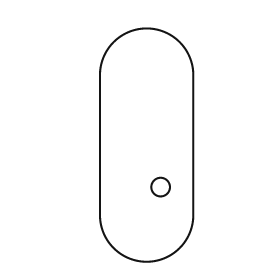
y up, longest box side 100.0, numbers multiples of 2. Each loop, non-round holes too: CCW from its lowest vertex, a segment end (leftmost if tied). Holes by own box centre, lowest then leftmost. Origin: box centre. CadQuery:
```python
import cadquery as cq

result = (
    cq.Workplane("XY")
    .moveTo(-20.0, -30.0)
    .threePointArc((0.0, -50.0), (20.0, -30.0))
    .lineTo(20.0, 30.0)
    .threePointArc((0.0, 50.0), (-20.0, 30.0))
    .close()
    .moveTo(6.0, -18.0)
    .circle(4.0)
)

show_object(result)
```